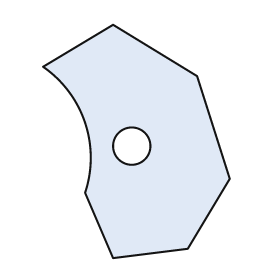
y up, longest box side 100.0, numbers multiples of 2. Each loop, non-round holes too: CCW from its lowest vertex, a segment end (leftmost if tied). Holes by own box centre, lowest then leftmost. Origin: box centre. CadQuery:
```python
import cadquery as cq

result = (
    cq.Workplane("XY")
    .moveTo(-10.0, -50.0)
    .lineTo(22.0, -46.0)
    .lineTo(40.0, -16.0)
    .lineTo(26.0, 28.0)
    .lineTo(-10.0, 50.0)
    .lineTo(-40.0, 32.0)
    .threePointArc((-22.0, 8.0), (-22.0, -22.0))
    .close()
    .moveTo(-2.0, -2.0)
    .circle(8.0)
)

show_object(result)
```